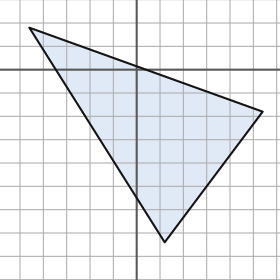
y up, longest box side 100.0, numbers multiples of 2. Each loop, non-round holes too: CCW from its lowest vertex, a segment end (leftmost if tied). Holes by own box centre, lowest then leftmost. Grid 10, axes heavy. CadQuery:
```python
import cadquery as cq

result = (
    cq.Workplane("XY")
    .moveTo(12.0, -74.0)
    .lineTo(54.0, -18.0)
    .lineTo(-46.0, 18.0)
    .close()
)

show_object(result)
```